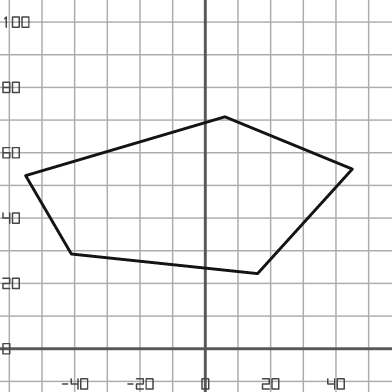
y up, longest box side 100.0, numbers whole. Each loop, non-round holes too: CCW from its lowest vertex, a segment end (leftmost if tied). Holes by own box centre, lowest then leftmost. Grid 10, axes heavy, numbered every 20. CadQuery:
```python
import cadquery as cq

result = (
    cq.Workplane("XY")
    .moveTo(16.0, 23.0)
    .lineTo(45.0, 55.0)
    .lineTo(6.0, 71.0)
    .lineTo(-55.0, 53.0)
    .lineTo(-41.0, 29.0)
    .close()
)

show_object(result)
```